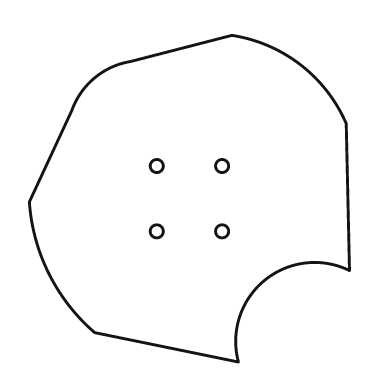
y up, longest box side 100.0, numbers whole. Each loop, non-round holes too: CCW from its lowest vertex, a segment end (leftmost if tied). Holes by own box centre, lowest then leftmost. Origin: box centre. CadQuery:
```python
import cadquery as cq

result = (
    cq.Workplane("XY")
    .moveTo(15.0, -50.0)
    .threePointArc((23.0, -25.0), (49.0, -22.0))
    .lineTo(48.0, 23.0)
    .threePointArc((34.0, 41.0), (13.0, 50.0))
    .lineTo(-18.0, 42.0)
    .threePointArc((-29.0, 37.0), (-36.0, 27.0))
    .lineTo(-49.0, -1.0)
    .threePointArc((-43.0, -23.0), (-29.0, -41.0))
    .close()
    .moveTo(-10.0, -10.0)
    .circle(2.0)
    .moveTo(10.0, -10.0)
    .circle(2.0)
    .moveTo(-10.0, 10.0)
    .circle(2.0)
    .moveTo(10.0, 10.0)
    .circle(2.0)
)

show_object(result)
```